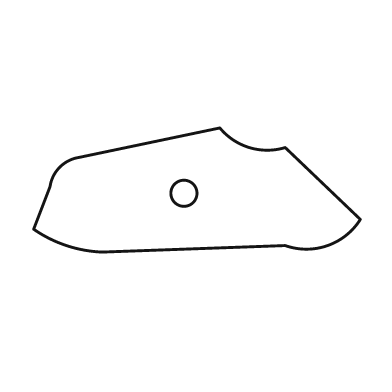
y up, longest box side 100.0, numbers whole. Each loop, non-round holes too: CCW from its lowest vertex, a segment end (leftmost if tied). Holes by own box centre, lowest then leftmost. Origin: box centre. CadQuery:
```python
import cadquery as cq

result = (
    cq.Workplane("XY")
    .moveTo(-29.0, -19.0)
    .lineTo(27.0, -17.0)
    .threePointArc((40.0, -17.0), (50.0, -9.0))
    .lineTo(27.0, 13.0)
    .threePointArc((16.0, 13.0), (7.0, 19.0))
    .lineTo(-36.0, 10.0)
    .threePointArc((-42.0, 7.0), (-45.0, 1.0))
    .lineTo(-50.0, -12.0)
    .threePointArc((-40.0, -17.0), (-29.0, -19.0))
    .close()
    .moveTo(-4.0, -1.0)
    .circle(4.0)
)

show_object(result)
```